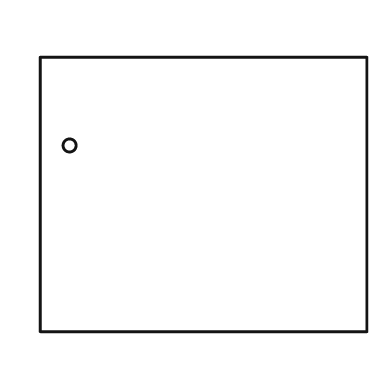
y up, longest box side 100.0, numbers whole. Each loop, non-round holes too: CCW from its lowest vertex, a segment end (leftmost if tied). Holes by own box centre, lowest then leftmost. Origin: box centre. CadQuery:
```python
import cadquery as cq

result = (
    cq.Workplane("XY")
    .moveTo(-50.0, -42.0)
    .lineTo(50.0, -42.0)
    .lineTo(50.0, 42.0)
    .lineTo(-50.0, 42.0)
    .close()
    .moveTo(-41.0, 15.0)
    .circle(2.0)
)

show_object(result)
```